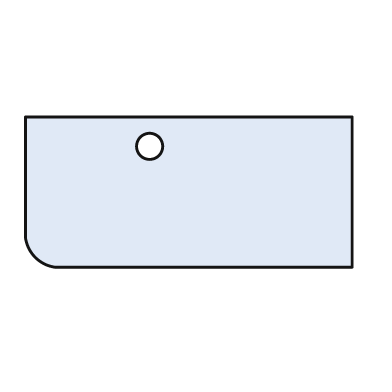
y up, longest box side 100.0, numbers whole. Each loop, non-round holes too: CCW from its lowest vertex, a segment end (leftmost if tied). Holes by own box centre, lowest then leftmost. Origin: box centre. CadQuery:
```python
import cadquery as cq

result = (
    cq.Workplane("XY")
    .moveTo(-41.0, -23.0)
    .lineTo(50.0, -23.0)
    .lineTo(50.0, 23.0)
    .lineTo(-50.0, 23.0)
    .lineTo(-50.0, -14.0)
    .threePointArc((-47.0, -20.0), (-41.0, -23.0))
    .close()
    .moveTo(-12.0, 14.0)
    .circle(4.0)
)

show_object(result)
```